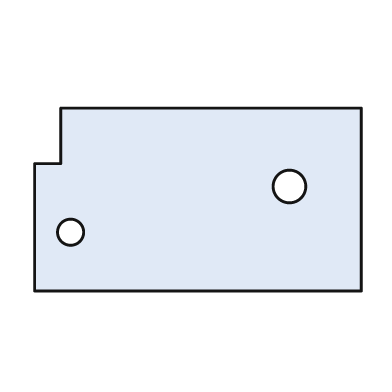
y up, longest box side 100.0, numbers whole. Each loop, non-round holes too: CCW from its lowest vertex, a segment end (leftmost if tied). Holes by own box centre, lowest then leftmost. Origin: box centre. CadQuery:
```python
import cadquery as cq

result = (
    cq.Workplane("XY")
    .moveTo(-50.0, -28.0)
    .lineTo(50.0, -28.0)
    .lineTo(50.0, 28.0)
    .lineTo(-42.0, 28.0)
    .lineTo(-42.0, 11.0)
    .lineTo(-50.0, 11.0)
    .close()
    .moveTo(-39.0, -10.0)
    .circle(4.0)
    .moveTo(28.0, 4.0)
    .circle(5.0)
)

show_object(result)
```